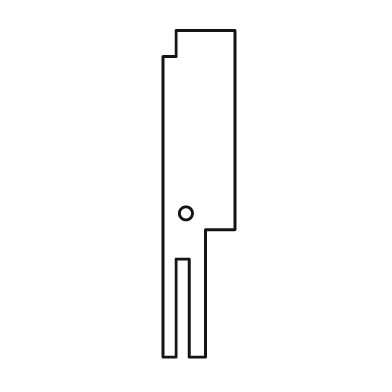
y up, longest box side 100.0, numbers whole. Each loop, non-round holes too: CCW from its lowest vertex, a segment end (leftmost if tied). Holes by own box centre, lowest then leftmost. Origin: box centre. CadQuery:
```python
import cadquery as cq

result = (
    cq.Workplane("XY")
    .moveTo(-11.0, -50.0)
    .lineTo(-7.0, -50.0)
    .lineTo(-7.0, -20.0)
    .lineTo(-3.0, -20.0)
    .lineTo(-3.0, -50.0)
    .lineTo(2.0, -50.0)
    .lineTo(2.0, -11.0)
    .lineTo(11.0, -11.0)
    .lineTo(11.0, 50.0)
    .lineTo(-7.0, 50.0)
    .lineTo(-7.0, 42.0)
    .lineTo(-11.0, 42.0)
    .close()
    .moveTo(-4.0, -6.0)
    .circle(2.0)
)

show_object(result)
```